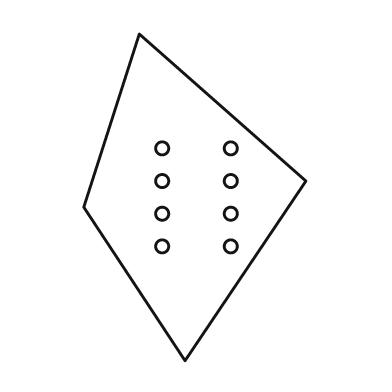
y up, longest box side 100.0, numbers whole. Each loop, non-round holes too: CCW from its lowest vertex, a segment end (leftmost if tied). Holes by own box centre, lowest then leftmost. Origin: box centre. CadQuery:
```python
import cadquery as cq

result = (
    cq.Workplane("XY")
    .moveTo(-3.0, -50.0)
    .lineTo(34.0, 5.0)
    .lineTo(-17.0, 50.0)
    .lineTo(-34.0, -3.0)
    .close()
    .moveTo(-10.0, -15.0)
    .circle(2.0)
    .moveTo(11.0, -15.0)
    .circle(2.0)
    .moveTo(-10.0, -5.0)
    .circle(2.0)
    .moveTo(11.0, -5.0)
    .circle(2.0)
    .moveTo(-10.0, 5.0)
    .circle(2.0)
    .moveTo(11.0, 5.0)
    .circle(2.0)
    .moveTo(-10.0, 15.0)
    .circle(2.0)
    .moveTo(11.0, 15.0)
    .circle(2.0)
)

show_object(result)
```